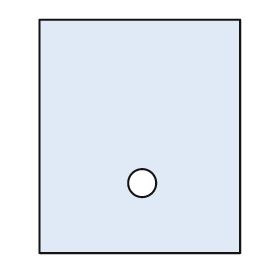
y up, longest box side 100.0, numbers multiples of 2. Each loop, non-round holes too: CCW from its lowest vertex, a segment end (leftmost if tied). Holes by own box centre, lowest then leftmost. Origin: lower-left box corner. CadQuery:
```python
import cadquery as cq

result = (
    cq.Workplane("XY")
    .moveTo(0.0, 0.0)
    .lineTo(86.0, 0.0)
    .lineTo(86.0, 100.0)
    .lineTo(0.0, 100.0)
    .close()
    .moveTo(44.0, 30.0)
    .circle(6.0)
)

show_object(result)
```